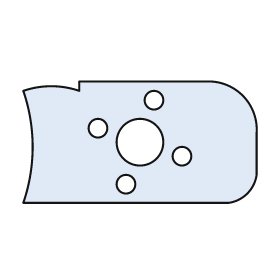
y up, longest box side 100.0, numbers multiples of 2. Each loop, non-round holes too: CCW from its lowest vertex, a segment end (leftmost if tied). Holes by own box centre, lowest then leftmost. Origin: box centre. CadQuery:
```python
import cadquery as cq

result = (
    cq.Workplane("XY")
    .moveTo(-50.0, -26.0)
    .lineTo(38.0, -26.0)
    .threePointArc((46.0, -22.0), (50.0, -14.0))
    .lineTo(50.0, 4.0)
    .threePointArc((44.0, 20.0), (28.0, 26.0))
    .lineTo(-26.0, 26.0)
    .lineTo(-26.0, 22.0)
    .threePointArc((-38.0, 24.0), (-50.0, 22.0))
    .threePointArc((-46.0, -2.0), (-50.0, -26.0))
    .close()
    .moveTo(-6.0, -18.0)
    .circle(4.0)
    .moveTo(18.0, -6.0)
    .circle(4.0)
    .moveTo(0.0, 0.0)
    .circle(10.0)
    .moveTo(-18.0, 6.0)
    .circle(4.0)
    .moveTo(6.0, 18.0)
    .circle(4.0)
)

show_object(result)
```